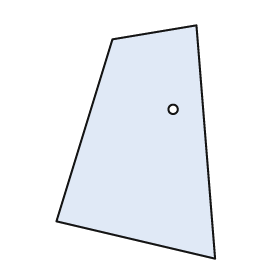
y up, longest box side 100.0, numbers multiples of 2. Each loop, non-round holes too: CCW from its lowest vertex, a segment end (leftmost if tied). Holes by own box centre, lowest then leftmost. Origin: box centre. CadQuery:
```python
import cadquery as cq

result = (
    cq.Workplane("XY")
    .moveTo(34.0, -50.0)
    .lineTo(26.0, 50.0)
    .lineTo(-10.0, 44.0)
    .lineTo(-34.0, -34.0)
    .close()
    .moveTo(16.0, 14.0)
    .circle(2.0)
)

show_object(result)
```